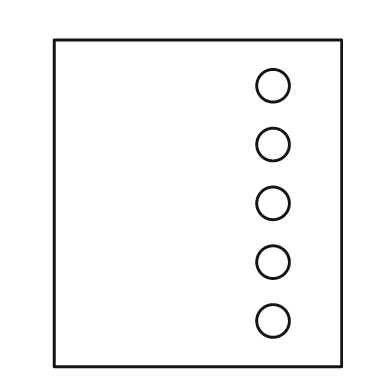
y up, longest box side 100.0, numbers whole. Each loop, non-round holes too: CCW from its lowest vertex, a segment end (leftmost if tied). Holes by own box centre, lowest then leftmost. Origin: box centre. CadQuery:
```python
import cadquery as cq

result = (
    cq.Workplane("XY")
    .moveTo(-44.0, -50.0)
    .lineTo(44.0, -50.0)
    .lineTo(44.0, 50.0)
    .lineTo(-44.0, 50.0)
    .close()
    .moveTo(23.0, -36.0)
    .circle(5.0)
    .moveTo(23.0, -18.0)
    .circle(5.0)
    .moveTo(23.0, 0.0)
    .circle(5.0)
    .moveTo(23.0, 18.0)
    .circle(5.0)
    .moveTo(23.0, 36.0)
    .circle(5.0)
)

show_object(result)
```